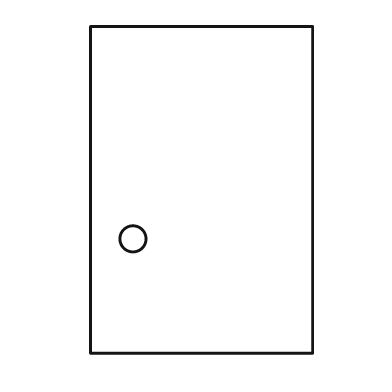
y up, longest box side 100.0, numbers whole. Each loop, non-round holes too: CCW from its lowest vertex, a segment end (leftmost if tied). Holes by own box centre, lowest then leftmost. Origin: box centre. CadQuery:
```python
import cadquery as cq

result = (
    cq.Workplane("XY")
    .moveTo(-34.0, -50.0)
    .lineTo(34.0, -50.0)
    .lineTo(34.0, 50.0)
    .lineTo(-34.0, 50.0)
    .close()
    .moveTo(-21.0, -15.0)
    .circle(4.0)
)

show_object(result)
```